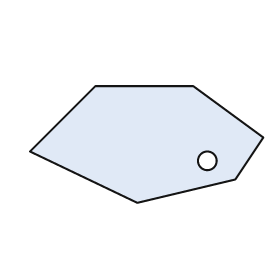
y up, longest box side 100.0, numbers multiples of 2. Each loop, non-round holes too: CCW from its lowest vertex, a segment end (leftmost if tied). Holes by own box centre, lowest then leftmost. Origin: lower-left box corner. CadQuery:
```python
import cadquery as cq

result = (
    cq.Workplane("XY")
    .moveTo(46.0, 0.0)
    .lineTo(88.0, 10.0)
    .lineTo(100.0, 28.0)
    .lineTo(70.0, 50.0)
    .lineTo(28.0, 50.0)
    .lineTo(0.0, 22.0)
    .close()
    .moveTo(76.0, 18.0)
    .circle(4.0)
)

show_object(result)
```